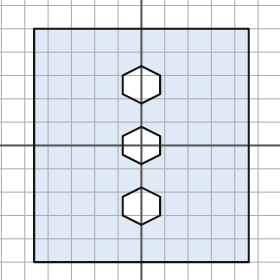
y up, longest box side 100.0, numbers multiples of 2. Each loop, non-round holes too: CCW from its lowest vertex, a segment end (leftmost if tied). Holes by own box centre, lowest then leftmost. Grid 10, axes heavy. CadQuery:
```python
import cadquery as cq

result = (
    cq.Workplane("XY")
    .moveTo(-46.0, -50.0)
    .lineTo(46.0, -50.0)
    .lineTo(46.0, 50.0)
    .lineTo(-46.0, 50.0)
    .close()
    .moveTo(0.0, -34.0)
    .lineTo(8.0, -30.0)
    .lineTo(8.0, -22.0)
    .lineTo(0.0, -18.0)
    .lineTo(-8.0, -22.0)
    .lineTo(-8.0, -30.0)
    .close()
    .moveTo(0.0, -8.0)
    .lineTo(8.0, -4.0)
    .lineTo(8.0, 4.0)
    .lineTo(0.0, 8.0)
    .lineTo(-8.0, 4.0)
    .lineTo(-8.0, -4.0)
    .close()
    .moveTo(0.0, 18.0)
    .lineTo(8.0, 22.0)
    .lineTo(8.0, 30.0)
    .lineTo(0.0, 34.0)
    .lineTo(-8.0, 30.0)
    .lineTo(-8.0, 22.0)
    .close()
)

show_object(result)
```